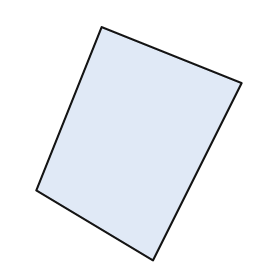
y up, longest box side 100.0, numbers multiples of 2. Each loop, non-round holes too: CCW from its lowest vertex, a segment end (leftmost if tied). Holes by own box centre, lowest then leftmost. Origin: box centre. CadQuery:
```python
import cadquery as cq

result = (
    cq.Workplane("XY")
    .moveTo(6.0, -50.0)
    .lineTo(44.0, 26.0)
    .lineTo(-16.0, 50.0)
    .lineTo(-44.0, -20.0)
    .close()
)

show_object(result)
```